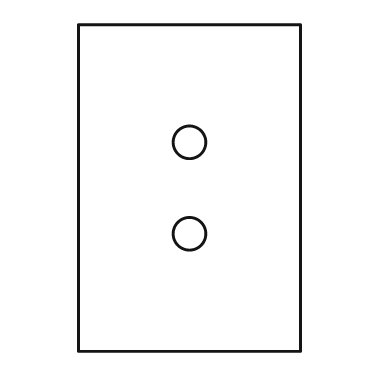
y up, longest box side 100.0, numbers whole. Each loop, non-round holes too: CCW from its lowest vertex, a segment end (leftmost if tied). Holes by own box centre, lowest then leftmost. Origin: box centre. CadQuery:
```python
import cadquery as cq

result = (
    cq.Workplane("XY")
    .moveTo(-34.0, -50.0)
    .lineTo(34.0, -50.0)
    .lineTo(34.0, 50.0)
    .lineTo(-34.0, 50.0)
    .close()
    .moveTo(0.0, -14.0)
    .circle(5.0)
    .moveTo(0.0, 14.0)
    .circle(5.0)
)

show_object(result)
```